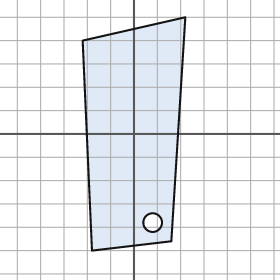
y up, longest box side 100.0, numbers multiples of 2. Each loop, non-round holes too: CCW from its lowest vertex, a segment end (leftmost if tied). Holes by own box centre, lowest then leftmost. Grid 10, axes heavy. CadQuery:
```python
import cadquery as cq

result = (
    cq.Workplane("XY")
    .moveTo(-18.0, -50.0)
    .lineTo(16.0, -46.0)
    .lineTo(22.0, 50.0)
    .lineTo(-22.0, 40.0)
    .close()
    .moveTo(8.0, -38.0)
    .circle(4.0)
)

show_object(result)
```